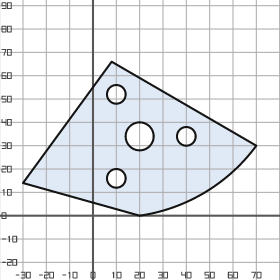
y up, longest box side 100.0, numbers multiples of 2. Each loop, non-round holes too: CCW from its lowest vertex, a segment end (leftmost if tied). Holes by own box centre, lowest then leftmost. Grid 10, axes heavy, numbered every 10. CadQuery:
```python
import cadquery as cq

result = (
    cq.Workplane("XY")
    .moveTo(20.0, 0.0)
    .threePointArc((48.0, 10.0), (70.0, 30.0))
    .lineTo(8.0, 66.0)
    .lineTo(-30.0, 14.0)
    .close()
    .moveTo(10.0, 16.0)
    .circle(4.0)
    .moveTo(20.0, 34.0)
    .circle(6.0)
    .moveTo(40.0, 34.0)
    .circle(4.0)
    .moveTo(10.0, 52.0)
    .circle(4.0)
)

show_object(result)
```